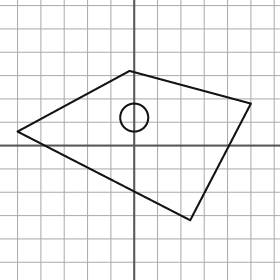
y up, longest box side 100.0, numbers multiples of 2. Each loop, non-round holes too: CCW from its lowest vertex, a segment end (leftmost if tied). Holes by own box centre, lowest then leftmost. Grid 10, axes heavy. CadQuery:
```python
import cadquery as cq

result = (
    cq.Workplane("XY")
    .moveTo(24.0, -32.0)
    .lineTo(50.0, 18.0)
    .lineTo(-2.0, 32.0)
    .lineTo(-50.0, 6.0)
    .close()
    .moveTo(0.0, 12.0)
    .circle(6.0)
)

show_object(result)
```